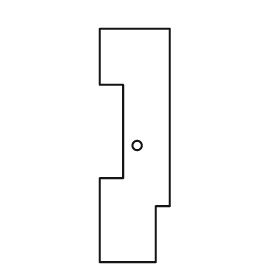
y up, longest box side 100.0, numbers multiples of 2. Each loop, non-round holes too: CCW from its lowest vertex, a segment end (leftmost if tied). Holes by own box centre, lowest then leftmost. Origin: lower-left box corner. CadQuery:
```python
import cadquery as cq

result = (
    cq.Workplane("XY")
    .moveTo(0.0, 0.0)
    .lineTo(24.0, 0.0)
    .lineTo(24.0, 24.0)
    .lineTo(30.0, 24.0)
    .lineTo(30.0, 100.0)
    .lineTo(0.0, 100.0)
    .lineTo(0.0, 76.0)
    .lineTo(10.0, 76.0)
    .lineTo(10.0, 36.0)
    .lineTo(0.0, 36.0)
    .close()
    .moveTo(16.0, 50.0)
    .circle(2.0)
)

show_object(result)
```